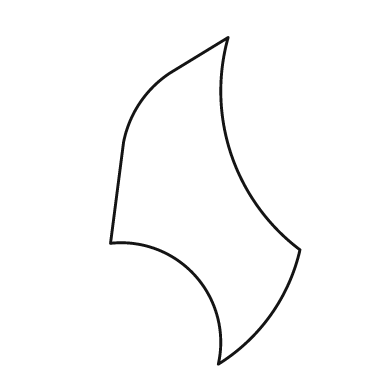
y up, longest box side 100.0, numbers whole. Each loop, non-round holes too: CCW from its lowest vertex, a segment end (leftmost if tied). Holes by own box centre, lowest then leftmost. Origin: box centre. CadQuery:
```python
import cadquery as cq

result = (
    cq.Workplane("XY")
    .moveTo(4.0, -50.0)
    .threePointArc((20.0, -35.0), (29.0, -15.0))
    .threePointArc((8.0, 14.0), (7.0, 50.0))
    .lineTo(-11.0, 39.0)
    .threePointArc((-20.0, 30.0), (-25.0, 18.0))
    .lineTo(-29.0, -13.0)
    .threePointArc((-3.0, -23.0), (4.0, -50.0))
    .close()
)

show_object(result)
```